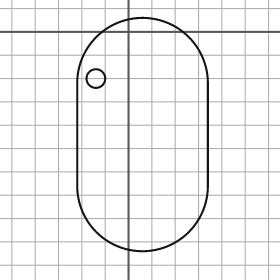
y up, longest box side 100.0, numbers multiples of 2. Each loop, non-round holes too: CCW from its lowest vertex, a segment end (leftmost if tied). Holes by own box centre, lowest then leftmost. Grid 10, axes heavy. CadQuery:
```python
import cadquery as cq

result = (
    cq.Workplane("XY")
    .moveTo(-22.0, -66.0)
    .threePointArc((6.0, -94.0), (34.0, -66.0))
    .lineTo(34.0, -22.0)
    .threePointArc((6.0, 6.0), (-22.0, -22.0))
    .close()
    .moveTo(-14.0, -20.0)
    .circle(4.0)
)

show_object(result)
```